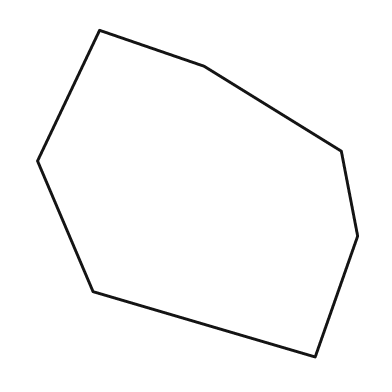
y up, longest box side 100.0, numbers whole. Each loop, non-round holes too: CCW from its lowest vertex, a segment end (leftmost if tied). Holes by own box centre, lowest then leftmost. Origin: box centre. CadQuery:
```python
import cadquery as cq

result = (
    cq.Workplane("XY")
    .moveTo(36.0, -50.0)
    .lineTo(49.0, -13.0)
    .lineTo(44.0, 13.0)
    .lineTo(2.0, 39.0)
    .lineTo(-30.0, 50.0)
    .lineTo(-49.0, 10.0)
    .lineTo(-32.0, -30.0)
    .close()
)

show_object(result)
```